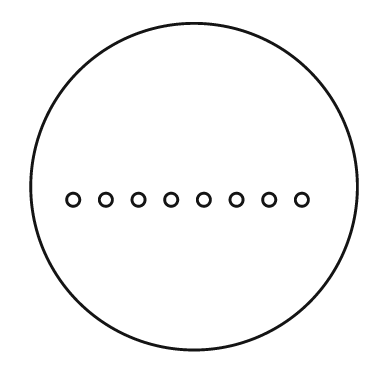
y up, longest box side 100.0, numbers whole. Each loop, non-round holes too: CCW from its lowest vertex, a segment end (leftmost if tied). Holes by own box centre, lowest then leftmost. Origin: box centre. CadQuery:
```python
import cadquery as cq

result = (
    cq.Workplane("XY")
    .moveTo(0.0, 0.0)
    .circle(50.0)
    .moveTo(-37.0, -4.0)
    .circle(2.0)
    .moveTo(-27.0, -4.0)
    .circle(2.0)
    .moveTo(-17.0, -4.0)
    .circle(2.0)
    .moveTo(-7.0, -4.0)
    .circle(2.0)
    .moveTo(3.0, -4.0)
    .circle(2.0)
    .moveTo(13.0, -4.0)
    .circle(2.0)
    .moveTo(23.0, -4.0)
    .circle(2.0)
    .moveTo(33.0, -4.0)
    .circle(2.0)
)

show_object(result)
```